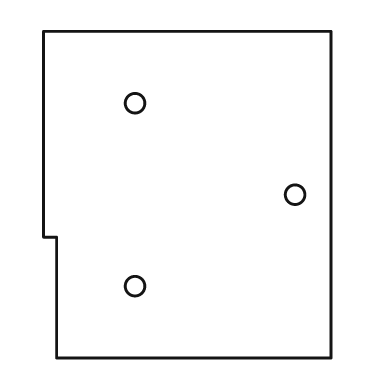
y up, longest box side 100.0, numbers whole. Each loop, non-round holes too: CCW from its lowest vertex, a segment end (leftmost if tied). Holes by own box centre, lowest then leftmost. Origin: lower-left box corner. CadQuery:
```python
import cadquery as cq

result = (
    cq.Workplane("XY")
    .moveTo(4.0, 0.0)
    .lineTo(88.0, 0.0)
    .lineTo(88.0, 100.0)
    .lineTo(0.0, 100.0)
    .lineTo(0.0, 37.0)
    .lineTo(4.0, 37.0)
    .close()
    .moveTo(28.0, 22.0)
    .circle(3.0)
    .moveTo(77.0, 50.0)
    .circle(3.0)
    .moveTo(28.0, 78.0)
    .circle(3.0)
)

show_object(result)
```